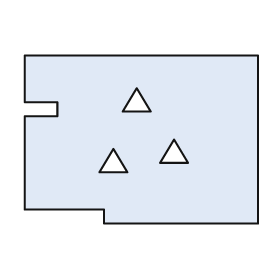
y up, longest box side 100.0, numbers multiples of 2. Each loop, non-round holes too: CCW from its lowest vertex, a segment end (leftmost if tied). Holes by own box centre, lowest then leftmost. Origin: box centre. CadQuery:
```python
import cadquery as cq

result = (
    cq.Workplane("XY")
    .moveTo(-16.0, -36.0)
    .lineTo(50.0, -36.0)
    .lineTo(50.0, 36.0)
    .lineTo(-50.0, 36.0)
    .lineTo(-50.0, 16.0)
    .lineTo(-36.0, 16.0)
    .lineTo(-36.0, 10.0)
    .lineTo(-50.0, 10.0)
    .lineTo(-50.0, -30.0)
    .lineTo(-16.0, -30.0)
    .close()
    .moveTo(-18.0, -14.0)
    .lineTo(-6.0, -14.0)
    .lineTo(-12.0, -4.0)
    .close()
    .moveTo(8.0, -10.0)
    .lineTo(20.0, -10.0)
    .lineTo(14.0, 0.0)
    .close()
    .moveTo(-8.0, 12.0)
    .lineTo(4.0, 12.0)
    .lineTo(-2.0, 22.0)
    .close()
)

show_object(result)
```